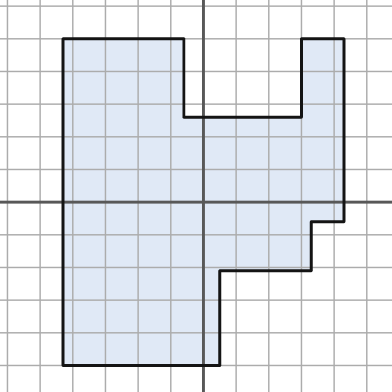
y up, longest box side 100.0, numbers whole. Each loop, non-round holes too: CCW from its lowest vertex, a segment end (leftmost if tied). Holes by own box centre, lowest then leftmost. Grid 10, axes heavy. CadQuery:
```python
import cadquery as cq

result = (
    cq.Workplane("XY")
    .moveTo(-43.0, -50.0)
    .lineTo(5.0, -50.0)
    .lineTo(5.0, -21.0)
    .lineTo(33.0, -21.0)
    .lineTo(33.0, -6.0)
    .lineTo(43.0, -6.0)
    .lineTo(43.0, 50.0)
    .lineTo(30.0, 50.0)
    .lineTo(30.0, 26.0)
    .lineTo(-6.0, 26.0)
    .lineTo(-6.0, 50.0)
    .lineTo(-43.0, 50.0)
    .close()
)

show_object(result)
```